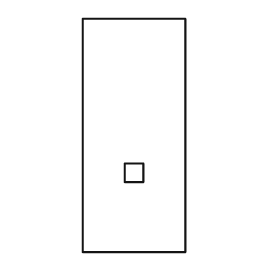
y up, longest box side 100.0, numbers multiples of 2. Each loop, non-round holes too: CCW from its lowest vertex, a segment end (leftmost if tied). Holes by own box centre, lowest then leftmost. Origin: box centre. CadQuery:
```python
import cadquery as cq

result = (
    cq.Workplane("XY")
    .moveTo(-22.0, -50.0)
    .lineTo(22.0, -50.0)
    .lineTo(22.0, 50.0)
    .lineTo(-22.0, 50.0)
    .close()
    .moveTo(-4.0, -20.0)
    .lineTo(4.0, -20.0)
    .lineTo(4.0, -12.0)
    .lineTo(-4.0, -12.0)
    .close()
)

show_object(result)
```